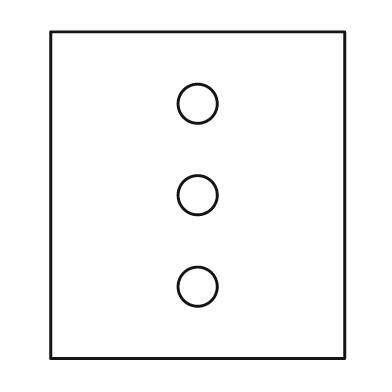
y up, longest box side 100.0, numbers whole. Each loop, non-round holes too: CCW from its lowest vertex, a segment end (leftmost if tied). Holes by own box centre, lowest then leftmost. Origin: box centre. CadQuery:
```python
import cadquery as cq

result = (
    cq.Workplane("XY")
    .moveTo(-45.0, -50.0)
    .lineTo(45.0, -50.0)
    .lineTo(45.0, 50.0)
    .lineTo(-45.0, 50.0)
    .close()
    .moveTo(0.0, -28.0)
    .circle(6.0)
    .moveTo(0.0, 0.0)
    .circle(6.0)
    .moveTo(0.0, 28.0)
    .circle(6.0)
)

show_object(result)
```